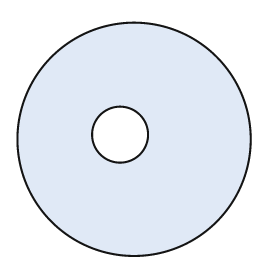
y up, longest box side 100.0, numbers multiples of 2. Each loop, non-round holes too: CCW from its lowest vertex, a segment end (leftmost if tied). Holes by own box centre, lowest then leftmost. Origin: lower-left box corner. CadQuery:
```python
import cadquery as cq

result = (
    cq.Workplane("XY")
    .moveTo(50.0, 50.0)
    .circle(50.0)
    .moveTo(44.0, 52.0)
    .circle(12.0)
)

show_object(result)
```